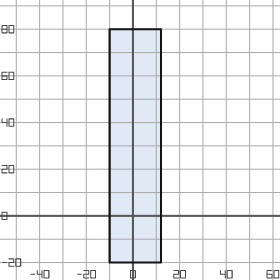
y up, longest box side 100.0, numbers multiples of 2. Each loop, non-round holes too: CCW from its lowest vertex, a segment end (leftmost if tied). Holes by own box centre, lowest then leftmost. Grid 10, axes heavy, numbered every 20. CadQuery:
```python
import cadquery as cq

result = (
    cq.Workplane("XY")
    .moveTo(-10.0, -20.0)
    .lineTo(12.0, -20.0)
    .lineTo(12.0, 80.0)
    .lineTo(-10.0, 80.0)
    .close()
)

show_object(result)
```